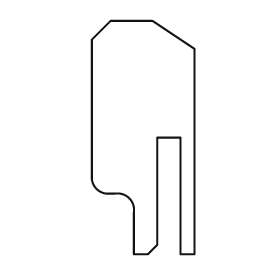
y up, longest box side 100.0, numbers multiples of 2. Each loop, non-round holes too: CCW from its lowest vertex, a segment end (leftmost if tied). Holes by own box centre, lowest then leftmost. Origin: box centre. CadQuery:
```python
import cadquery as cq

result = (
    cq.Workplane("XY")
    .moveTo(-4.0, -50.0)
    .lineTo(2.0, -50.0)
    .lineTo(6.0, -46.0)
    .lineTo(6.0, 0.0)
    .lineTo(16.0, 0.0)
    .lineTo(16.0, -50.0)
    .lineTo(22.0, -50.0)
    .lineTo(22.0, 38.0)
    .lineTo(4.0, 50.0)
    .lineTo(-14.0, 50.0)
    .lineTo(-22.0, 42.0)
    .lineTo(-22.0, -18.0)
    .threePointArc((-20.0, -22.0), (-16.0, -24.0))
    .lineTo(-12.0, -24.0)
    .threePointArc((-6.0, -26.0), (-4.0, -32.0))
    .close()
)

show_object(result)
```